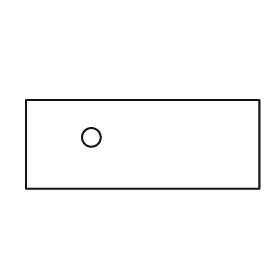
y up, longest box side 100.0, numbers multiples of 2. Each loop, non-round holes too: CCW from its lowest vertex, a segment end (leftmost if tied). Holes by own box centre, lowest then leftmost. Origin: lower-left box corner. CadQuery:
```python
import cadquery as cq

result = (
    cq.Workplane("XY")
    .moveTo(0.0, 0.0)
    .lineTo(100.0, 0.0)
    .lineTo(100.0, 38.0)
    .lineTo(0.0, 38.0)
    .close()
    .moveTo(28.0, 22.0)
    .circle(4.0)
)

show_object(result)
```